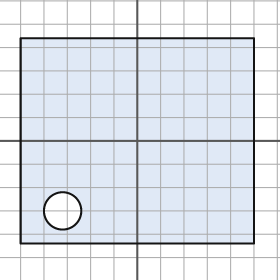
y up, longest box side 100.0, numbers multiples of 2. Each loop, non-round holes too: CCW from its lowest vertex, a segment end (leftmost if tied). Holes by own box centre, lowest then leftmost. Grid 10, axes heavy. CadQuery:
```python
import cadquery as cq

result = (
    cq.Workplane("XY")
    .moveTo(-50.0, -44.0)
    .lineTo(50.0, -44.0)
    .lineTo(50.0, 44.0)
    .lineTo(-50.0, 44.0)
    .close()
    .moveTo(-32.0, -30.0)
    .circle(8.0)
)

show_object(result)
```